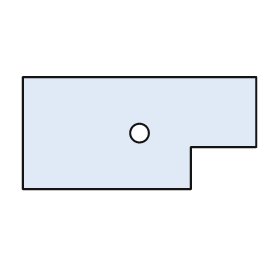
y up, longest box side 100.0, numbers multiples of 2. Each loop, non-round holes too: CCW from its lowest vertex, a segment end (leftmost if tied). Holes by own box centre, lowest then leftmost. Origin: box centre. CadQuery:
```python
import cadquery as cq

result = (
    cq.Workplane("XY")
    .moveTo(-50.0, -24.0)
    .lineTo(22.0, -24.0)
    .lineTo(22.0, -6.0)
    .lineTo(50.0, -6.0)
    .lineTo(50.0, 24.0)
    .lineTo(-50.0, 24.0)
    .close()
    .moveTo(0.0, 0.0)
    .circle(4.0)
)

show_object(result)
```